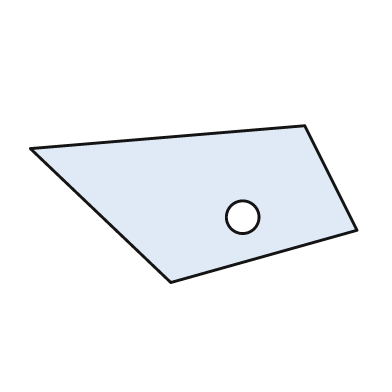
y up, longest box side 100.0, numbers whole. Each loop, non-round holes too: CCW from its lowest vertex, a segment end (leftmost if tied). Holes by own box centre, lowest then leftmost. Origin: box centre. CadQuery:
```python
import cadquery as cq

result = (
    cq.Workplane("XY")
    .moveTo(-7.0, -24.0)
    .lineTo(50.0, -8.0)
    .lineTo(34.0, 24.0)
    .lineTo(-50.0, 17.0)
    .close()
    .moveTo(15.0, -4.0)
    .circle(5.0)
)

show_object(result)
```